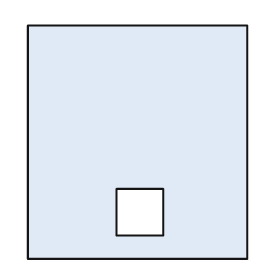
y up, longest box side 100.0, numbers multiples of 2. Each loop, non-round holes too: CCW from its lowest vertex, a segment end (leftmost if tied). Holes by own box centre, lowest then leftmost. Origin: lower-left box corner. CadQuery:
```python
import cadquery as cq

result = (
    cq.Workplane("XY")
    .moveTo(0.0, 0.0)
    .lineTo(94.0, 0.0)
    .lineTo(94.0, 100.0)
    .lineTo(0.0, 100.0)
    .close()
    .moveTo(38.0, 10.0)
    .lineTo(58.0, 10.0)
    .lineTo(58.0, 30.0)
    .lineTo(38.0, 30.0)
    .close()
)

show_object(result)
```